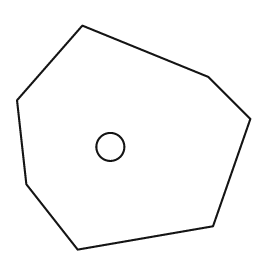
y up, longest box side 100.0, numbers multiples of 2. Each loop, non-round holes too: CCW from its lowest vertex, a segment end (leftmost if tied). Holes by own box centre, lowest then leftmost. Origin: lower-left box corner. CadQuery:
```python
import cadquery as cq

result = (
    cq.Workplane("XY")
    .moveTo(26.0, 0.0)
    .lineTo(84.0, 10.0)
    .lineTo(100.0, 56.0)
    .lineTo(82.0, 74.0)
    .lineTo(28.0, 96.0)
    .lineTo(0.0, 64.0)
    .lineTo(4.0, 28.0)
    .close()
    .moveTo(40.0, 44.0)
    .circle(6.0)
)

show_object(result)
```